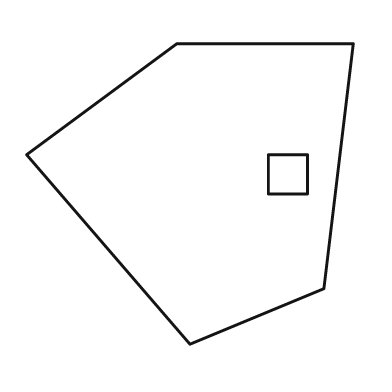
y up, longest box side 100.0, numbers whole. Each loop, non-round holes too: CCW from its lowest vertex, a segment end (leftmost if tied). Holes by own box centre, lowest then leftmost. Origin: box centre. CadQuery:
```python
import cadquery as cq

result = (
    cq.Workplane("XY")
    .moveTo(0.0, -46.0)
    .lineTo(41.0, -29.0)
    .lineTo(50.0, 46.0)
    .lineTo(-4.0, 46.0)
    .lineTo(-50.0, 12.0)
    .close()
    .moveTo(24.0, 0.0)
    .lineTo(36.0, 0.0)
    .lineTo(36.0, 12.0)
    .lineTo(24.0, 12.0)
    .close()
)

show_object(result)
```